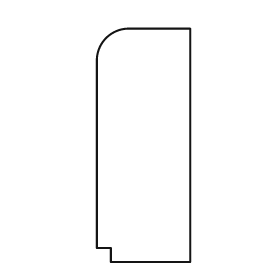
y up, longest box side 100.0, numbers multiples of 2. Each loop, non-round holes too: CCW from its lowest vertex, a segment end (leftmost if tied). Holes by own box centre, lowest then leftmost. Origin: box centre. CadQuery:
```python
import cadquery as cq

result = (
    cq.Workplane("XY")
    .moveTo(-14.0, -50.0)
    .lineTo(20.0, -50.0)
    .lineTo(20.0, 50.0)
    .lineTo(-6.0, 50.0)
    .threePointArc((-16.0, 46.0), (-20.0, 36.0))
    .lineTo(-20.0, -44.0)
    .lineTo(-14.0, -44.0)
    .close()
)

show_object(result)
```